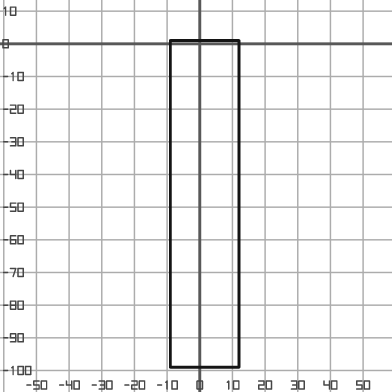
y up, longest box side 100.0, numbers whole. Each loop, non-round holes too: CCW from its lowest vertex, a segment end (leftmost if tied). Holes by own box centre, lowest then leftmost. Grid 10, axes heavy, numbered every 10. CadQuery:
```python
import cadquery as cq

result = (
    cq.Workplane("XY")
    .moveTo(-9.0, -99.0)
    .lineTo(12.0, -99.0)
    .lineTo(12.0, 1.0)
    .lineTo(-9.0, 1.0)
    .close()
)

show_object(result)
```